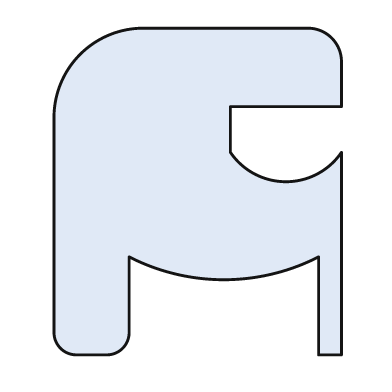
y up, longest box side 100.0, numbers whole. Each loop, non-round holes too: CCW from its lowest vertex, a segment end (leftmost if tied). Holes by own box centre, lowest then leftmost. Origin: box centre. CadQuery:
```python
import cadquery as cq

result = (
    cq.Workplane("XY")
    .moveTo(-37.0, -50.0)
    .lineTo(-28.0, -50.0)
    .threePointArc((-23.0, -48.0), (-21.0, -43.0))
    .lineTo(-21.0, -20.0)
    .threePointArc((8.0, -27.0), (37.0, -20.0))
    .lineTo(37.0, -50.0)
    .lineTo(44.0, -50.0)
    .lineTo(44.0, 12.0)
    .threePointArc((27.0, 3.0), (10.0, 12.0))
    .lineTo(10.0, 26.0)
    .lineTo(44.0, 26.0)
    .lineTo(44.0, 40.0)
    .threePointArc((41.0, 47.0), (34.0, 50.0))
    .lineTo(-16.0, 50.0)
    .threePointArc((-36.0, 42.0), (-44.0, 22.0))
    .lineTo(-44.0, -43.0)
    .threePointArc((-42.0, -48.0), (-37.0, -50.0))
    .close()
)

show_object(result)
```